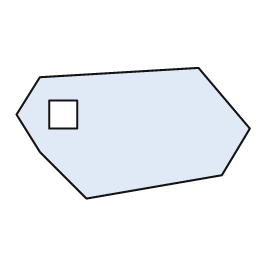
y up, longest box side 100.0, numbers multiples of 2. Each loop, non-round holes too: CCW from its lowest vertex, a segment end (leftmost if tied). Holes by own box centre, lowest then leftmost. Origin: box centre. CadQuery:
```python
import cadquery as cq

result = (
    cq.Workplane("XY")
    .moveTo(-20.0, -28.0)
    .lineTo(38.0, -18.0)
    .lineTo(50.0, 2.0)
    .lineTo(28.0, 28.0)
    .lineTo(-40.0, 24.0)
    .lineTo(-50.0, 8.0)
    .lineTo(-40.0, -8.0)
    .close()
    .moveTo(-36.0, 2.0)
    .lineTo(-24.0, 2.0)
    .lineTo(-24.0, 14.0)
    .lineTo(-36.0, 14.0)
    .close()
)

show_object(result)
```